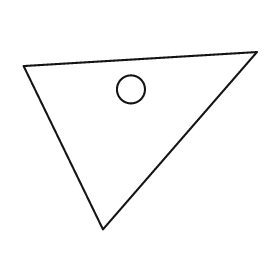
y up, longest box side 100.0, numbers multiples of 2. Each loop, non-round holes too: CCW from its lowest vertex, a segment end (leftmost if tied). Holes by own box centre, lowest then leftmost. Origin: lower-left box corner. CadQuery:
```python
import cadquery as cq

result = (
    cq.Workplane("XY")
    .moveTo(34.0, 0.0)
    .lineTo(100.0, 76.0)
    .lineTo(0.0, 70.0)
    .close()
    .moveTo(46.0, 60.0)
    .circle(6.0)
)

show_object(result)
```